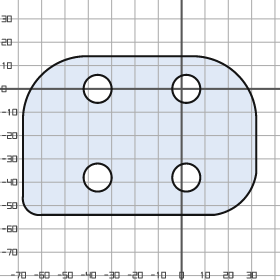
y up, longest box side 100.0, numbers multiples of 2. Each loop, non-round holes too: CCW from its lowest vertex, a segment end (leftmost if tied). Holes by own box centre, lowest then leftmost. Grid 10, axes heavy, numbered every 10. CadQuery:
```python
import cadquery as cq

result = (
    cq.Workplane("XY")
    .moveTo(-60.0, -54.0)
    .lineTo(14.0, -54.0)
    .threePointArc((26.0, -48.0), (32.0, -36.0))
    .lineTo(32.0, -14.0)
    .threePointArc((24.0, 6.0), (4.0, 14.0))
    .lineTo(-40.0, 14.0)
    .threePointArc((-60.0, 6.0), (-68.0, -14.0))
    .lineTo(-68.0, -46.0)
    .threePointArc((-66.0, -52.0), (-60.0, -54.0))
    .close()
    .moveTo(-36.0, -38.0)
    .circle(6.0)
    .moveTo(2.0, -38.0)
    .circle(6.0)
    .moveTo(-36.0, 0.0)
    .circle(6.0)
    .moveTo(2.0, 0.0)
    .circle(6.0)
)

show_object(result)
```